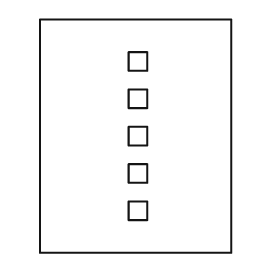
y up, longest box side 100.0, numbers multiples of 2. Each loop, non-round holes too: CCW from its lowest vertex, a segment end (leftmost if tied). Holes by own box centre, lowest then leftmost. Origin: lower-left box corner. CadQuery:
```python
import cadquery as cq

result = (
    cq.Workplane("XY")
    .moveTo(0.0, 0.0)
    .lineTo(82.0, 0.0)
    .lineTo(82.0, 100.0)
    .lineTo(0.0, 100.0)
    .close()
    .moveTo(38.0, 14.0)
    .lineTo(46.0, 14.0)
    .lineTo(46.0, 22.0)
    .lineTo(38.0, 22.0)
    .close()
    .moveTo(38.0, 30.0)
    .lineTo(46.0, 30.0)
    .lineTo(46.0, 38.0)
    .lineTo(38.0, 38.0)
    .close()
    .moveTo(38.0, 46.0)
    .lineTo(46.0, 46.0)
    .lineTo(46.0, 54.0)
    .lineTo(38.0, 54.0)
    .close()
    .moveTo(38.0, 62.0)
    .lineTo(46.0, 62.0)
    .lineTo(46.0, 70.0)
    .lineTo(38.0, 70.0)
    .close()
    .moveTo(38.0, 78.0)
    .lineTo(46.0, 78.0)
    .lineTo(46.0, 86.0)
    .lineTo(38.0, 86.0)
    .close()
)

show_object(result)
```